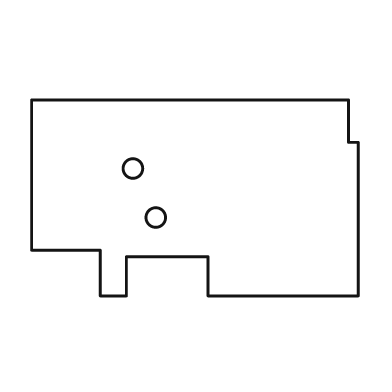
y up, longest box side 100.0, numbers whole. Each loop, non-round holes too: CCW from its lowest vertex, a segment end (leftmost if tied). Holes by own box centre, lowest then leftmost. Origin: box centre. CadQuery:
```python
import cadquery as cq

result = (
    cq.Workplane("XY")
    .moveTo(-29.0, -30.0)
    .lineTo(-21.0, -30.0)
    .lineTo(-21.0, -18.0)
    .lineTo(4.0, -18.0)
    .lineTo(4.0, -30.0)
    .lineTo(50.0, -30.0)
    .lineTo(50.0, 17.0)
    .lineTo(47.0, 17.0)
    .lineTo(47.0, 30.0)
    .lineTo(-50.0, 30.0)
    .lineTo(-50.0, -16.0)
    .lineTo(-29.0, -16.0)
    .close()
    .moveTo(-12.0, -6.0)
    .circle(3.0)
    .moveTo(-19.0, 9.0)
    .circle(3.0)
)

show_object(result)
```